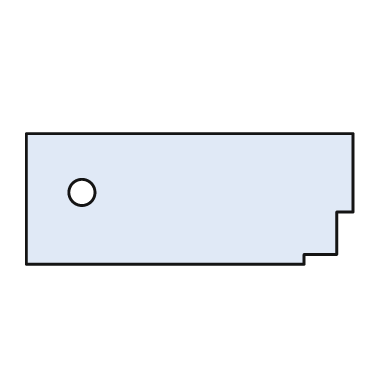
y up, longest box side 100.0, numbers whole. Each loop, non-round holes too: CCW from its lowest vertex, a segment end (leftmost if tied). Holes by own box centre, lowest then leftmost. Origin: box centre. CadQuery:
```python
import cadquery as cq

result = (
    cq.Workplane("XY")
    .moveTo(-50.0, -20.0)
    .lineTo(35.0, -20.0)
    .lineTo(35.0, -17.0)
    .lineTo(45.0, -17.0)
    .lineTo(45.0, -4.0)
    .lineTo(50.0, -4.0)
    .lineTo(50.0, 20.0)
    .lineTo(-50.0, 20.0)
    .close()
    .moveTo(-33.0, 2.0)
    .circle(4.0)
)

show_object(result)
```